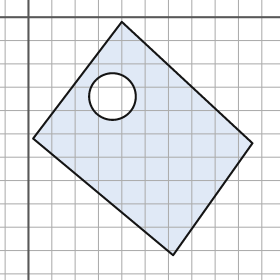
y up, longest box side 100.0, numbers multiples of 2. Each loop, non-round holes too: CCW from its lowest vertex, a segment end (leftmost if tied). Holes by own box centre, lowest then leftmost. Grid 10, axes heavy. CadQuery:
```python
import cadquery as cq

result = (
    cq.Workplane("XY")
    .moveTo(62.0, -102.0)
    .lineTo(96.0, -54.0)
    .lineTo(40.0, -2.0)
    .lineTo(2.0, -52.0)
    .close()
    .moveTo(36.0, -34.0)
    .circle(10.0)
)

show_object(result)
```